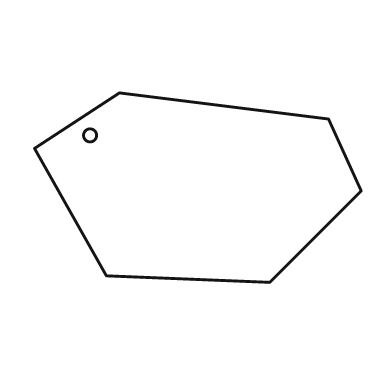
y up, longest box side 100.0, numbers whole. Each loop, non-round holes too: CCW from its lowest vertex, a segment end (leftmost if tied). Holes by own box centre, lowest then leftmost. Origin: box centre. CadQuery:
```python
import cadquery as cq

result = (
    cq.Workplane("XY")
    .moveTo(22.0, -29.0)
    .lineTo(50.0, -1.0)
    .lineTo(40.0, 21.0)
    .lineTo(-24.0, 29.0)
    .lineTo(-50.0, 12.0)
    .lineTo(-28.0, -27.0)
    .close()
    .moveTo(-33.0, 16.0)
    .circle(2.0)
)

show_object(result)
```